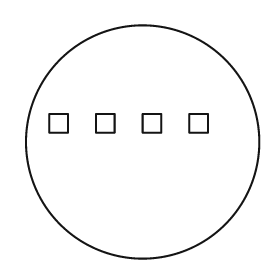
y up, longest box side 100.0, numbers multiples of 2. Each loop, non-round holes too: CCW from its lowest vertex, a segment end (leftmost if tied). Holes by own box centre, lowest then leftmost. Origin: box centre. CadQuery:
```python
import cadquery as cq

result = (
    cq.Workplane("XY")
    .moveTo(0.0, 0.0)
    .circle(50.0)
    .moveTo(-40.0, 4.0)
    .lineTo(-32.0, 4.0)
    .lineTo(-32.0, 12.0)
    .lineTo(-40.0, 12.0)
    .close()
    .moveTo(-20.0, 4.0)
    .lineTo(-12.0, 4.0)
    .lineTo(-12.0, 12.0)
    .lineTo(-20.0, 12.0)
    .close()
    .moveTo(0.0, 4.0)
    .lineTo(8.0, 4.0)
    .lineTo(8.0, 12.0)
    .lineTo(0.0, 12.0)
    .close()
    .moveTo(20.0, 4.0)
    .lineTo(28.0, 4.0)
    .lineTo(28.0, 12.0)
    .lineTo(20.0, 12.0)
    .close()
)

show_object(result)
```